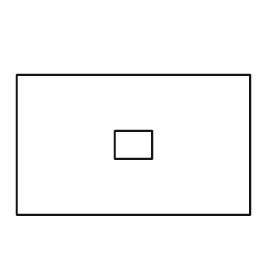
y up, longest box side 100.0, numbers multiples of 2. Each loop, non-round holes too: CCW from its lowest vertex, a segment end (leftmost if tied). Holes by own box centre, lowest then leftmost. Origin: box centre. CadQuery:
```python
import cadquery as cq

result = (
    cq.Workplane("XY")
    .moveTo(-50.0, -30.0)
    .lineTo(50.0, -30.0)
    .lineTo(50.0, 30.0)
    .lineTo(-50.0, 30.0)
    .close()
    .moveTo(-8.0, -6.0)
    .lineTo(8.0, -6.0)
    .lineTo(8.0, 6.0)
    .lineTo(-8.0, 6.0)
    .close()
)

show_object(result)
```